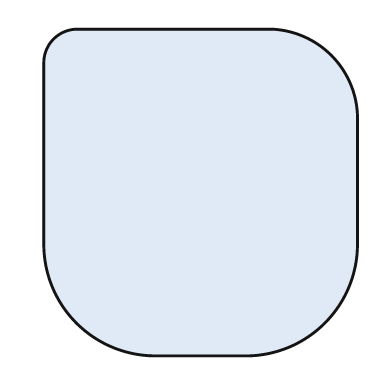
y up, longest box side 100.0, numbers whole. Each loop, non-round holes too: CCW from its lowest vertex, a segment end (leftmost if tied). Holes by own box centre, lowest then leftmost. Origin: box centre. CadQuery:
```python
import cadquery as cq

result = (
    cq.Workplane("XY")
    .moveTo(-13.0, -50.0)
    .lineTo(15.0, -50.0)
    .threePointArc((38.0, -40.0), (48.0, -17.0))
    .lineTo(48.0, 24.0)
    .threePointArc((40.0, 42.0), (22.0, 50.0))
    .lineTo(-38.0, 50.0)
    .threePointArc((-45.0, 47.0), (-48.0, 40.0))
    .lineTo(-48.0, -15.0)
    .threePointArc((-38.0, -40.0), (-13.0, -50.0))
    .close()
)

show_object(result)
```